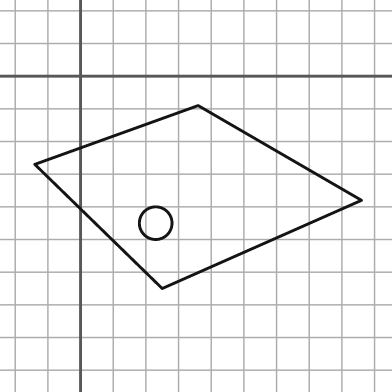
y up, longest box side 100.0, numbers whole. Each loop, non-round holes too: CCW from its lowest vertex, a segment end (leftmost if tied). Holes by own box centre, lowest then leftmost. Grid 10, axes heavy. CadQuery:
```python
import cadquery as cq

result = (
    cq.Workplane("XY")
    .moveTo(25.0, -65.0)
    .lineTo(86.0, -38.0)
    .lineTo(36.0, -9.0)
    .lineTo(-14.0, -27.0)
    .close()
    .moveTo(23.0, -45.0)
    .circle(5.0)
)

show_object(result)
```